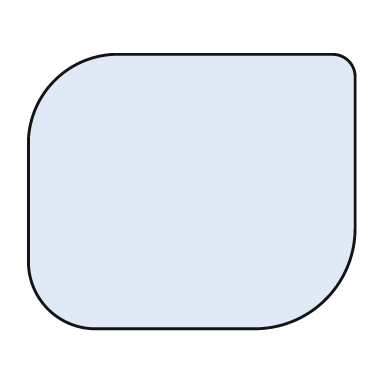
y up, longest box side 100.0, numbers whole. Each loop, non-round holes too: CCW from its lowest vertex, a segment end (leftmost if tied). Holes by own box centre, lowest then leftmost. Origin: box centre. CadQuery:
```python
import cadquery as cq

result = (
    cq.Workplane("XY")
    .moveTo(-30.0, -42.0)
    .lineTo(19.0, -42.0)
    .threePointArc((41.0, -33.0), (50.0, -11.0))
    .lineTo(50.0, 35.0)
    .threePointArc((48.0, 40.0), (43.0, 42.0))
    .lineTo(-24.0, 42.0)
    .threePointArc((-42.0, 34.0), (-50.0, 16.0))
    .lineTo(-50.0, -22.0)
    .threePointArc((-44.0, -36.0), (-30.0, -42.0))
    .close()
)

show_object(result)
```